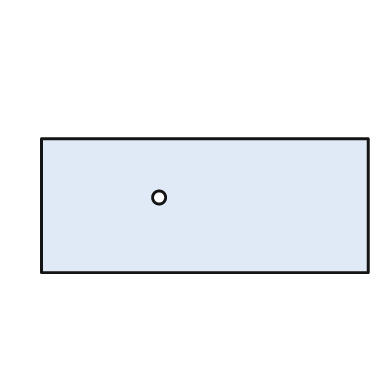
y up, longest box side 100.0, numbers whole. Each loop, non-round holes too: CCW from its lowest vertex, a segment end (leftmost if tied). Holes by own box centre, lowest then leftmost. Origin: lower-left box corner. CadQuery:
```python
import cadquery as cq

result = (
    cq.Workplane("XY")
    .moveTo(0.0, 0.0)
    .lineTo(100.0, 0.0)
    .lineTo(100.0, 41.0)
    .lineTo(0.0, 41.0)
    .close()
    .moveTo(36.0, 23.0)
    .circle(2.0)
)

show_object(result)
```